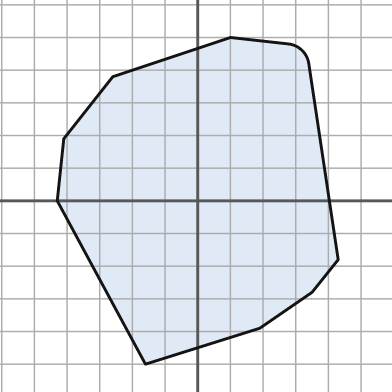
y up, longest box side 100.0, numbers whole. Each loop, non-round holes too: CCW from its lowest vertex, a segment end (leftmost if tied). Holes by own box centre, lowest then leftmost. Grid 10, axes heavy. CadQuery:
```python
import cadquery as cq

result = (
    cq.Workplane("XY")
    .moveTo(-16.0, -50.0)
    .lineTo(19.0, -39.0)
    .lineTo(35.0, -28.0)
    .lineTo(43.0, -18.0)
    .lineTo(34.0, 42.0)
    .threePointArc((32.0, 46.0), (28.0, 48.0))
    .lineTo(10.0, 50.0)
    .lineTo(-26.0, 38.0)
    .lineTo(-41.0, 19.0)
    .lineTo(-43.0, 0.0)
    .close()
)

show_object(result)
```